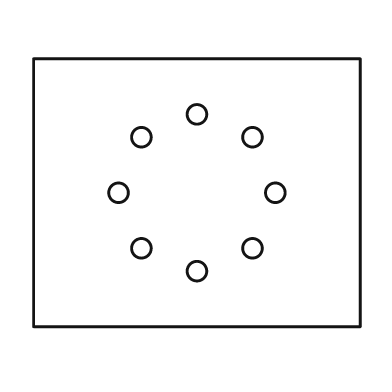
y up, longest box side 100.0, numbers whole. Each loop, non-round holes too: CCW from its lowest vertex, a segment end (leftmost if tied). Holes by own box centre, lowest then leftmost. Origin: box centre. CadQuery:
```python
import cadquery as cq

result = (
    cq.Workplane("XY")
    .moveTo(-50.0, -41.0)
    .lineTo(50.0, -41.0)
    .lineTo(50.0, 41.0)
    .lineTo(-50.0, 41.0)
    .close()
    .moveTo(0.0, -24.0)
    .circle(3.0)
    .moveTo(-17.0, -17.0)
    .circle(3.0)
    .moveTo(17.0, -17.0)
    .circle(3.0)
    .moveTo(-24.0, 0.0)
    .circle(3.0)
    .moveTo(24.0, 0.0)
    .circle(3.0)
    .moveTo(-17.0, 17.0)
    .circle(3.0)
    .moveTo(17.0, 17.0)
    .circle(3.0)
    .moveTo(0.0, 24.0)
    .circle(3.0)
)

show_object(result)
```